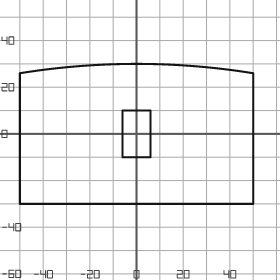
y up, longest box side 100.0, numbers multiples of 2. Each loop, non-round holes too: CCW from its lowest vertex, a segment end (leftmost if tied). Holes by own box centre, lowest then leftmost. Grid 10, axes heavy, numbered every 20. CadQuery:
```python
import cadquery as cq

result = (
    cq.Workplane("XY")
    .moveTo(-50.0, -30.0)
    .lineTo(50.0, -30.0)
    .lineTo(50.0, 26.0)
    .threePointArc((0.0, 30.0), (-50.0, 26.0))
    .close()
    .moveTo(-6.0, -10.0)
    .lineTo(6.0, -10.0)
    .lineTo(6.0, 10.0)
    .lineTo(-6.0, 10.0)
    .close()
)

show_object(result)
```